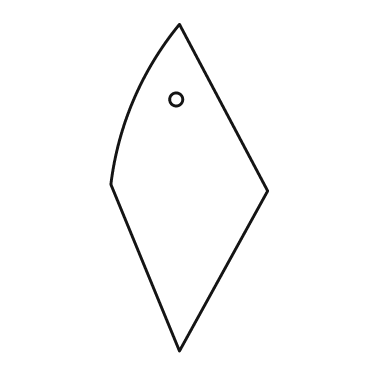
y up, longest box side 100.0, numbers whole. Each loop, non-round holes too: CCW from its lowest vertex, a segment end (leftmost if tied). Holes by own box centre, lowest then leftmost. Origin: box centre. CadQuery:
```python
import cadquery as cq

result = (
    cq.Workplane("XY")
    .moveTo(-3.0, -50.0)
    .lineTo(24.0, -1.0)
    .lineTo(-3.0, 50.0)
    .threePointArc((-17.0, 27.0), (-24.0, 1.0))
    .close()
    .moveTo(-4.0, 27.0)
    .circle(2.0)
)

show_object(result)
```